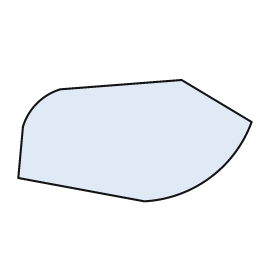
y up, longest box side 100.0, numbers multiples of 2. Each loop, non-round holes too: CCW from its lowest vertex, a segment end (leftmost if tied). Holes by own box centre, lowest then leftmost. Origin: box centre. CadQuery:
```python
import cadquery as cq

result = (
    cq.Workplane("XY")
    .moveTo(4.0, -26.0)
    .threePointArc((32.0, -16.0), (50.0, 8.0))
    .lineTo(20.0, 26.0)
    .lineTo(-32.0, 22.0)
    .threePointArc((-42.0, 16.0), (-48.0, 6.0))
    .lineTo(-50.0, -16.0)
    .close()
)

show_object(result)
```